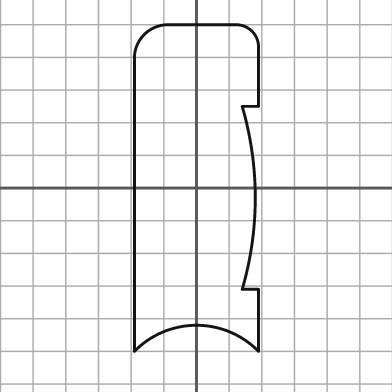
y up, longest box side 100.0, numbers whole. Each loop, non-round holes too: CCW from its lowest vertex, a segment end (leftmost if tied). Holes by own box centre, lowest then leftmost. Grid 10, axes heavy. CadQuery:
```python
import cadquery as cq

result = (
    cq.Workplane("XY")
    .moveTo(-19.0, -50.0)
    .threePointArc((0.0, -42.0), (19.0, -50.0))
    .lineTo(19.0, -31.0)
    .lineTo(14.0, -31.0)
    .threePointArc((18.0, -3.0), (14.0, 25.0))
    .lineTo(19.0, 25.0)
    .lineTo(19.0, 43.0)
    .threePointArc((17.0, 48.0), (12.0, 50.0))
    .lineTo(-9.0, 50.0)
    .threePointArc((-16.0, 47.0), (-19.0, 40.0))
    .close()
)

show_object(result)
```